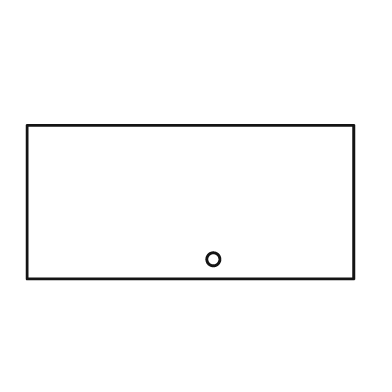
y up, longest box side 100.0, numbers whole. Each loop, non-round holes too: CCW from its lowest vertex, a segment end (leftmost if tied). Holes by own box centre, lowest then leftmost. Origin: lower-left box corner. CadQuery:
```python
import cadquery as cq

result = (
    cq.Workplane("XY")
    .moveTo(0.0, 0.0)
    .lineTo(100.0, 0.0)
    .lineTo(100.0, 47.0)
    .lineTo(0.0, 47.0)
    .close()
    .moveTo(57.0, 6.0)
    .circle(2.0)
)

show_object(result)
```